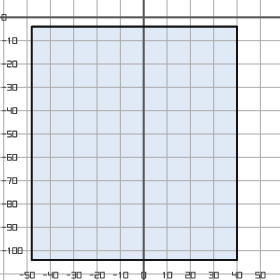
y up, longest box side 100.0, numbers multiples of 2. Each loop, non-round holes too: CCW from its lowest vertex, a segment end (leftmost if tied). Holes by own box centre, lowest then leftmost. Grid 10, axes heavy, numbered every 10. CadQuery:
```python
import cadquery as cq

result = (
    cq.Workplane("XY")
    .moveTo(-48.0, -104.0)
    .lineTo(40.0, -104.0)
    .lineTo(40.0, -4.0)
    .lineTo(-48.0, -4.0)
    .close()
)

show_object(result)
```